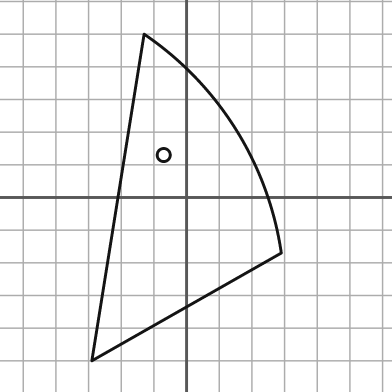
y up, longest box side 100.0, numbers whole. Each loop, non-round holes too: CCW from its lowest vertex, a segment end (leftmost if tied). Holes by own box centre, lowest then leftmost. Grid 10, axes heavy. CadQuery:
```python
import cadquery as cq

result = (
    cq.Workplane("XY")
    .moveTo(-29.0, -50.0)
    .lineTo(29.0, -17.0)
    .threePointArc((15.0, 21.0), (-13.0, 50.0))
    .close()
    .moveTo(-7.0, 13.0)
    .circle(2.0)
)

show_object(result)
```